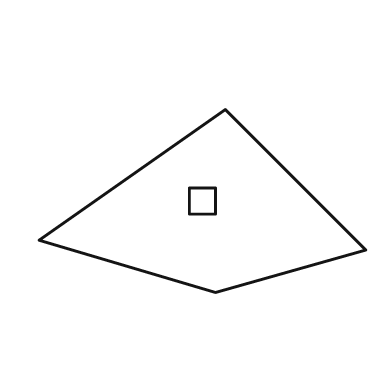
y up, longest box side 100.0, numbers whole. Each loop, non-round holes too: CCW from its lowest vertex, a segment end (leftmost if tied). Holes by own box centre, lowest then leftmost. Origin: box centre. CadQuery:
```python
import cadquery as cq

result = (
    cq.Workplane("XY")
    .moveTo(4.0, -28.0)
    .lineTo(50.0, -15.0)
    .lineTo(7.0, 28.0)
    .lineTo(-50.0, -12.0)
    .close()
    .moveTo(-4.0, -4.0)
    .lineTo(4.0, -4.0)
    .lineTo(4.0, 4.0)
    .lineTo(-4.0, 4.0)
    .close()
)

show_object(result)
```